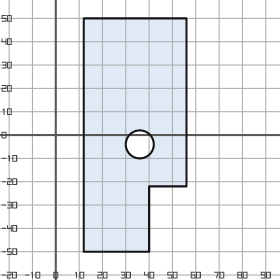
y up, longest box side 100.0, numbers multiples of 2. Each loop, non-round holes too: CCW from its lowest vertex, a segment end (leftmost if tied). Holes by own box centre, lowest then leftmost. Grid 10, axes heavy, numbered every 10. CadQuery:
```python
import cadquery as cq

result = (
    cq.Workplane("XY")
    .moveTo(12.0, -50.0)
    .lineTo(40.0, -50.0)
    .lineTo(40.0, -22.0)
    .lineTo(56.0, -22.0)
    .lineTo(56.0, 50.0)
    .lineTo(12.0, 50.0)
    .close()
    .moveTo(36.0, -4.0)
    .circle(6.0)
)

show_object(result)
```